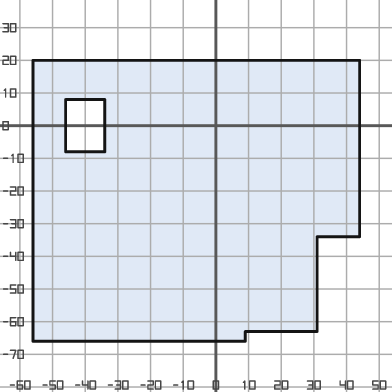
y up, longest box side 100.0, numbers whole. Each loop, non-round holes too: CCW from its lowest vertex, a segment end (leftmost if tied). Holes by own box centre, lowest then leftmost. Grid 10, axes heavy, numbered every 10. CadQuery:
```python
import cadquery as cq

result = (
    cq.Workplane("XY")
    .moveTo(-56.0, -66.0)
    .lineTo(9.0, -66.0)
    .lineTo(9.0, -63.0)
    .lineTo(31.0, -63.0)
    .lineTo(31.0, -34.0)
    .lineTo(44.0, -34.0)
    .lineTo(44.0, 20.0)
    .lineTo(-56.0, 20.0)
    .close()
    .moveTo(-46.0, -8.0)
    .lineTo(-34.0, -8.0)
    .lineTo(-34.0, 8.0)
    .lineTo(-46.0, 8.0)
    .close()
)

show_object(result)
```